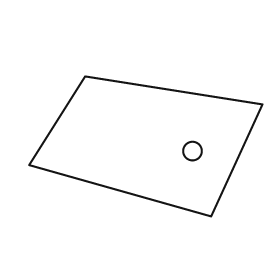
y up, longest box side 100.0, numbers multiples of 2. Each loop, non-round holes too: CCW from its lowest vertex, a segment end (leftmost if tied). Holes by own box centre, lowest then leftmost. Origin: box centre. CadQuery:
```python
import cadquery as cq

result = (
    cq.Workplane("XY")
    .moveTo(28.0, -30.0)
    .lineTo(50.0, 18.0)
    .lineTo(-26.0, 30.0)
    .lineTo(-50.0, -8.0)
    .close()
    .moveTo(20.0, -2.0)
    .circle(4.0)
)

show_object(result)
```